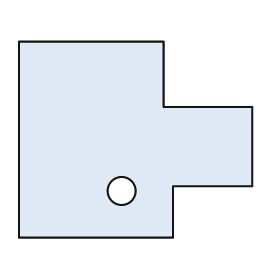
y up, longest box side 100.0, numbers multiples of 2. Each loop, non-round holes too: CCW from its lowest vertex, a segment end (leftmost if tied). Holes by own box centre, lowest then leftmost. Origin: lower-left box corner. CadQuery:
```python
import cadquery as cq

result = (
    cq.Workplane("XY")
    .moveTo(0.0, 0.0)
    .lineTo(66.0, 0.0)
    .lineTo(66.0, 22.0)
    .lineTo(100.0, 22.0)
    .lineTo(100.0, 56.0)
    .lineTo(62.0, 56.0)
    .lineTo(62.0, 84.0)
    .lineTo(0.0, 84.0)
    .close()
    .moveTo(44.0, 20.0)
    .circle(6.0)
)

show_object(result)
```